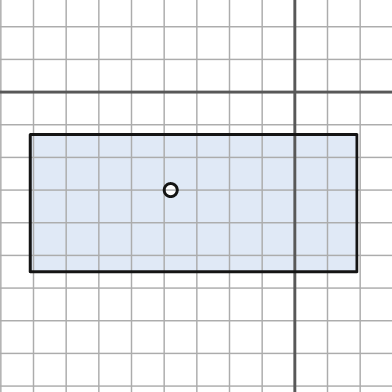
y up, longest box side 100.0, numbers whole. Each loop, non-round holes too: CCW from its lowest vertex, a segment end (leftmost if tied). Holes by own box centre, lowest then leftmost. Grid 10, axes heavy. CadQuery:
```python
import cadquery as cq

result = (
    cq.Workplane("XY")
    .moveTo(-81.0, -55.0)
    .lineTo(19.0, -55.0)
    .lineTo(19.0, -13.0)
    .lineTo(-81.0, -13.0)
    .close()
    .moveTo(-38.0, -30.0)
    .circle(2.0)
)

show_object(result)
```